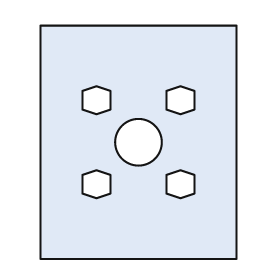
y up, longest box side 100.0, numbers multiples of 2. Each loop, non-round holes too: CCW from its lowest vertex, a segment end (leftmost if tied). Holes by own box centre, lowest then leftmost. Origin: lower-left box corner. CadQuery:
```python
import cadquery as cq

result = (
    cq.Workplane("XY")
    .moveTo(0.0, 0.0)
    .lineTo(84.0, 0.0)
    .lineTo(84.0, 100.0)
    .lineTo(0.0, 100.0)
    .close()
    .moveTo(24.0, 26.0)
    .lineTo(30.0, 28.0)
    .lineTo(30.0, 36.0)
    .lineTo(24.0, 38.0)
    .lineTo(18.0, 36.0)
    .lineTo(18.0, 28.0)
    .close()
    .moveTo(60.0, 26.0)
    .lineTo(66.0, 28.0)
    .lineTo(66.0, 36.0)
    .lineTo(60.0, 38.0)
    .lineTo(54.0, 36.0)
    .lineTo(54.0, 28.0)
    .close()
    .moveTo(42.0, 50.0)
    .circle(10.0)
    .moveTo(24.0, 62.0)
    .lineTo(30.0, 64.0)
    .lineTo(30.0, 72.0)
    .lineTo(24.0, 74.0)
    .lineTo(18.0, 72.0)
    .lineTo(18.0, 64.0)
    .close()
    .moveTo(60.0, 62.0)
    .lineTo(66.0, 64.0)
    .lineTo(66.0, 72.0)
    .lineTo(60.0, 74.0)
    .lineTo(54.0, 72.0)
    .lineTo(54.0, 64.0)
    .close()
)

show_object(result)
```